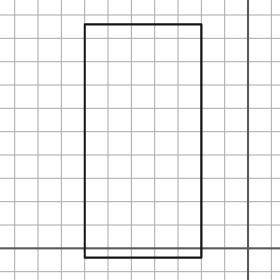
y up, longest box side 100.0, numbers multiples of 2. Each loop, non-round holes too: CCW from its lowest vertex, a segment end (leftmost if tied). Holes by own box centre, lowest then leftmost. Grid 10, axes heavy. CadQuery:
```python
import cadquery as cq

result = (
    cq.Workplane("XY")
    .moveTo(-70.0, -4.0)
    .lineTo(-20.0, -4.0)
    .lineTo(-20.0, 96.0)
    .lineTo(-70.0, 96.0)
    .close()
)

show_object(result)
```